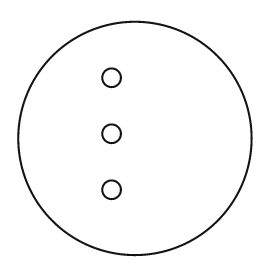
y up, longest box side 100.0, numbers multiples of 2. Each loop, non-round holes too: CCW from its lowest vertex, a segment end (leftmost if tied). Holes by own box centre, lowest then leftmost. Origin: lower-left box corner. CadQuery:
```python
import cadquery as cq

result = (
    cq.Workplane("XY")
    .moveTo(50.0, 50.0)
    .circle(50.0)
    .moveTo(40.0, 28.0)
    .circle(4.0)
    .moveTo(40.0, 52.0)
    .circle(4.0)
    .moveTo(40.0, 76.0)
    .circle(4.0)
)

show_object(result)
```